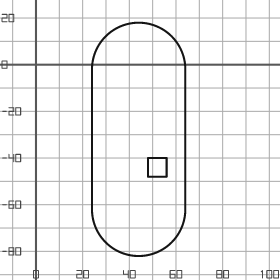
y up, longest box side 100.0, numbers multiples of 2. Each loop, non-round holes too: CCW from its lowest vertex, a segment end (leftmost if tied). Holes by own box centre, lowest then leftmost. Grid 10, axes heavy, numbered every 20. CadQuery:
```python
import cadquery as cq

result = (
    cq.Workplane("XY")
    .moveTo(24.0, -62.0)
    .threePointArc((44.0, -82.0), (64.0, -62.0))
    .lineTo(64.0, -2.0)
    .threePointArc((44.0, 18.0), (24.0, -2.0))
    .close()
    .moveTo(48.0, -48.0)
    .lineTo(56.0, -48.0)
    .lineTo(56.0, -40.0)
    .lineTo(48.0, -40.0)
    .close()
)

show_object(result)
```